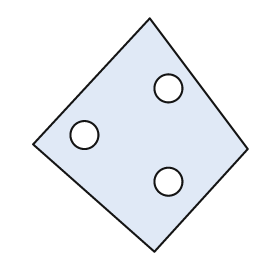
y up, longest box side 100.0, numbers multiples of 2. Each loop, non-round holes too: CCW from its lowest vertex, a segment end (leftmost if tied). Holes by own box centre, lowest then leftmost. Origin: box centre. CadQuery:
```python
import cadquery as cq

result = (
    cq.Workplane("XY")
    .moveTo(6.0, -50.0)
    .lineTo(46.0, -6.0)
    .lineTo(4.0, 50.0)
    .lineTo(-46.0, -4.0)
    .close()
    .moveTo(12.0, -20.0)
    .circle(6.0)
    .moveTo(-24.0, 0.0)
    .circle(6.0)
    .moveTo(12.0, 20.0)
    .circle(6.0)
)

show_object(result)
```